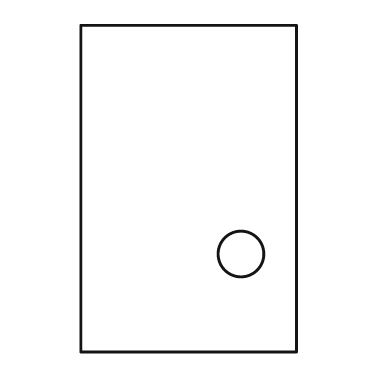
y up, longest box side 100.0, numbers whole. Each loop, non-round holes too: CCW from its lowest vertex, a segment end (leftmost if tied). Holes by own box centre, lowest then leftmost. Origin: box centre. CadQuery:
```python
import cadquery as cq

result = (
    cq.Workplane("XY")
    .moveTo(-33.0, -50.0)
    .lineTo(33.0, -50.0)
    .lineTo(33.0, 50.0)
    .lineTo(-33.0, 50.0)
    .close()
    .moveTo(16.0, -20.0)
    .circle(7.0)
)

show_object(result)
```